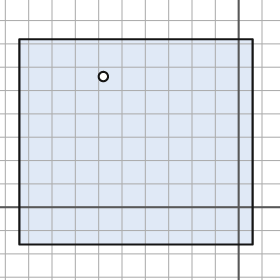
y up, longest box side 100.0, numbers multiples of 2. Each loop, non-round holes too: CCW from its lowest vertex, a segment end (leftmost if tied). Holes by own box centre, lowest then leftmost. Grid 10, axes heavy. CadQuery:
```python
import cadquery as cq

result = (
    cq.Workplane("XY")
    .moveTo(-94.0, -16.0)
    .lineTo(6.0, -16.0)
    .lineTo(6.0, 72.0)
    .lineTo(-94.0, 72.0)
    .close()
    .moveTo(-58.0, 56.0)
    .circle(2.0)
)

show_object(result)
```